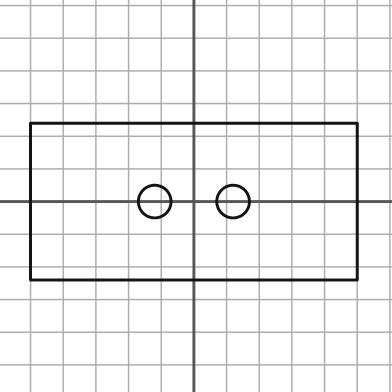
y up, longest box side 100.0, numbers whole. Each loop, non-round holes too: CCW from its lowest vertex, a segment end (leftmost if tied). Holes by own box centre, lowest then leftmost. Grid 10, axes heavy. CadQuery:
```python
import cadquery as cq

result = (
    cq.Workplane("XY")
    .moveTo(-50.0, -24.0)
    .lineTo(50.0, -24.0)
    .lineTo(50.0, 24.0)
    .lineTo(-50.0, 24.0)
    .close()
    .moveTo(-12.0, 0.0)
    .circle(5.0)
    .moveTo(12.0, 0.0)
    .circle(5.0)
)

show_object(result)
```